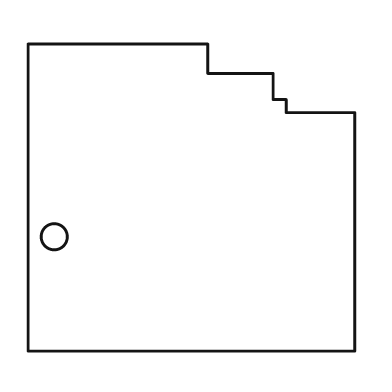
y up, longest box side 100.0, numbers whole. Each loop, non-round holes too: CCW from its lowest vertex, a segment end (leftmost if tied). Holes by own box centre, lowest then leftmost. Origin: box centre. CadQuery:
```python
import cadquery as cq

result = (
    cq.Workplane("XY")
    .moveTo(-50.0, -47.0)
    .lineTo(50.0, -47.0)
    .lineTo(50.0, 26.0)
    .lineTo(29.0, 26.0)
    .lineTo(29.0, 30.0)
    .lineTo(25.0, 30.0)
    .lineTo(25.0, 38.0)
    .lineTo(5.0, 38.0)
    .lineTo(5.0, 47.0)
    .lineTo(-50.0, 47.0)
    .close()
    .moveTo(-42.0, -12.0)
    .circle(4.0)
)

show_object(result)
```